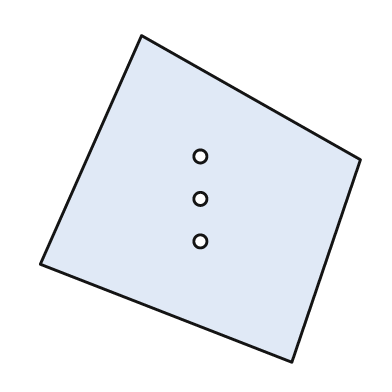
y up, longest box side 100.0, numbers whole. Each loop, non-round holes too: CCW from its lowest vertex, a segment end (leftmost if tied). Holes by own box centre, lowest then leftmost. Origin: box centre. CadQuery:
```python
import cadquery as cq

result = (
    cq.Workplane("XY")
    .moveTo(28.0, -50.0)
    .lineTo(49.0, 12.0)
    .lineTo(-18.0, 50.0)
    .lineTo(-49.0, -20.0)
    .close()
    .moveTo(0.0, -13.0)
    .circle(2.0)
    .moveTo(0.0, 0.0)
    .circle(2.0)
    .moveTo(0.0, 13.0)
    .circle(2.0)
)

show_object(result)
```